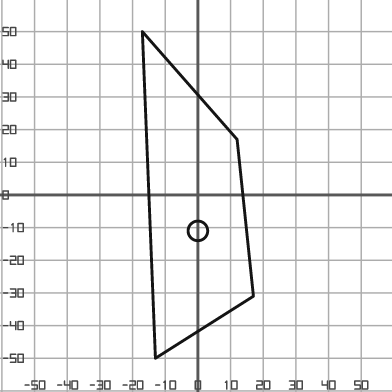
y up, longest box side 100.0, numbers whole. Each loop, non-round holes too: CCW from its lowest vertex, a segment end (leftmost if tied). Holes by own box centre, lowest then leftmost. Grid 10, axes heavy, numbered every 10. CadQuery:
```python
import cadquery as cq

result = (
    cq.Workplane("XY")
    .moveTo(-13.0, -50.0)
    .lineTo(17.0, -31.0)
    .lineTo(12.0, 17.0)
    .lineTo(-17.0, 50.0)
    .close()
    .moveTo(0.0, -11.0)
    .circle(3.0)
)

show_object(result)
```